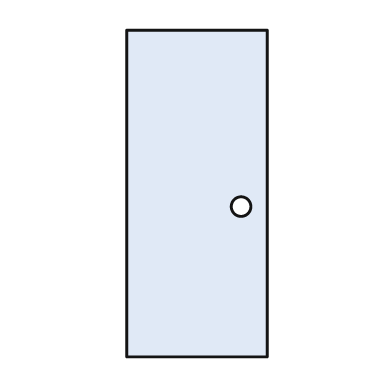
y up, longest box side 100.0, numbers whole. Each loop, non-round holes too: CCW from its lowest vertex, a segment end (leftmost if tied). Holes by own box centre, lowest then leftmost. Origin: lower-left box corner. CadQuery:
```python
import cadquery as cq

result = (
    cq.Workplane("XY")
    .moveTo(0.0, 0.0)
    .lineTo(43.0, 0.0)
    .lineTo(43.0, 100.0)
    .lineTo(0.0, 100.0)
    .close()
    .moveTo(35.0, 46.0)
    .circle(3.0)
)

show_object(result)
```